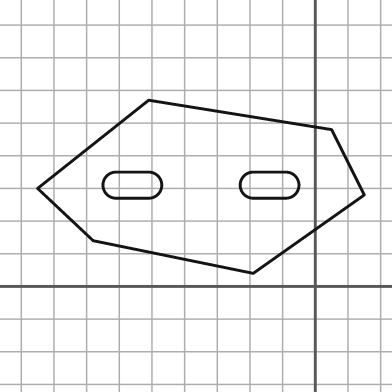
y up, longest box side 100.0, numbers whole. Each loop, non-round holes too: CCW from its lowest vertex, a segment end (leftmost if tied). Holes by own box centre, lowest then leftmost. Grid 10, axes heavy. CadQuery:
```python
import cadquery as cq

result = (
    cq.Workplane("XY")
    .moveTo(-19.0, 4.0)
    .lineTo(15.0, 28.0)
    .lineTo(5.0, 48.0)
    .lineTo(-51.0, 57.0)
    .lineTo(-85.0, 30.0)
    .lineTo(-68.0, 14.0)
    .close()
    .moveTo(-61.0, 27.0)
    .lineTo(-51.0, 27.0)
    .threePointArc((-47.0, 31.0), (-51.0, 35.0))
    .lineTo(-61.0, 35.0)
    .threePointArc((-65.0, 31.0), (-61.0, 27.0))
    .close()
    .moveTo(-19.0, 27.0)
    .lineTo(-9.0, 27.0)
    .threePointArc((-5.0, 31.0), (-9.0, 35.0))
    .lineTo(-19.0, 35.0)
    .threePointArc((-23.0, 31.0), (-19.0, 27.0))
    .close()
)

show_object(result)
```